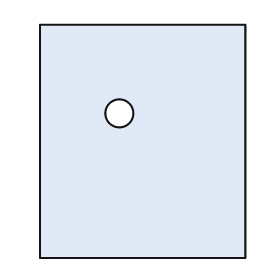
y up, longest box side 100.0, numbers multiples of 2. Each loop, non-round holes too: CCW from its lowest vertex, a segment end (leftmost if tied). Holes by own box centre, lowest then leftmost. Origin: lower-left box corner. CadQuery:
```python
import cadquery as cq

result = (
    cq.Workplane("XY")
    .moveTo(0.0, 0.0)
    .lineTo(88.0, 0.0)
    .lineTo(88.0, 100.0)
    .lineTo(0.0, 100.0)
    .close()
    .moveTo(34.0, 62.0)
    .circle(6.0)
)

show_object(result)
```